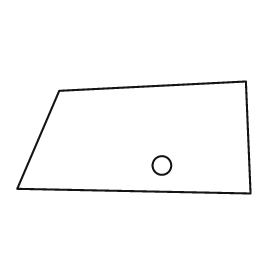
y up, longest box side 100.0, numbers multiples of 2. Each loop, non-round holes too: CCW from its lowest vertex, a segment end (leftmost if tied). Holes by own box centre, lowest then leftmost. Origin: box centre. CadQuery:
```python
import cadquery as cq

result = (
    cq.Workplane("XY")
    .moveTo(50.0, -24.0)
    .lineTo(48.0, 24.0)
    .lineTo(-32.0, 20.0)
    .lineTo(-50.0, -22.0)
    .close()
    .moveTo(12.0, -12.0)
    .circle(4.0)
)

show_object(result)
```